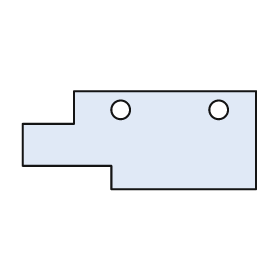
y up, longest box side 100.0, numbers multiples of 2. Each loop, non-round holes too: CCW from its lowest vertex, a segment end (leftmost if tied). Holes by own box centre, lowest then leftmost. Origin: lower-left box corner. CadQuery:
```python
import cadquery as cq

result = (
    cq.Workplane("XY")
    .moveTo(38.0, 0.0)
    .lineTo(100.0, 0.0)
    .lineTo(100.0, 42.0)
    .lineTo(22.0, 42.0)
    .lineTo(22.0, 28.0)
    .lineTo(0.0, 28.0)
    .lineTo(0.0, 10.0)
    .lineTo(38.0, 10.0)
    .close()
    .moveTo(42.0, 34.0)
    .circle(4.0)
    .moveTo(84.0, 34.0)
    .circle(4.0)
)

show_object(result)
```